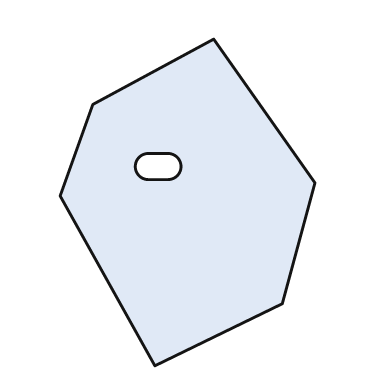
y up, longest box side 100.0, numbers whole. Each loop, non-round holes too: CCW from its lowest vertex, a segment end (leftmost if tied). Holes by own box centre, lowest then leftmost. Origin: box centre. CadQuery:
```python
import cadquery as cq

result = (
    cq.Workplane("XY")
    .moveTo(-10.0, -50.0)
    .lineTo(29.0, -31.0)
    .lineTo(39.0, 6.0)
    .lineTo(8.0, 50.0)
    .lineTo(-29.0, 30.0)
    .lineTo(-39.0, 2.0)
    .close()
    .moveTo(-12.0, 7.0)
    .lineTo(-6.0, 7.0)
    .threePointArc((-2.0, 11.0), (-6.0, 15.0))
    .lineTo(-12.0, 15.0)
    .threePointArc((-16.0, 11.0), (-12.0, 7.0))
    .close()
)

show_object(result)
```